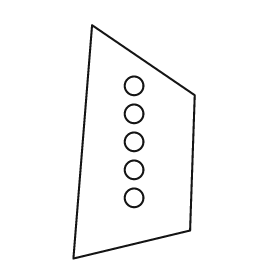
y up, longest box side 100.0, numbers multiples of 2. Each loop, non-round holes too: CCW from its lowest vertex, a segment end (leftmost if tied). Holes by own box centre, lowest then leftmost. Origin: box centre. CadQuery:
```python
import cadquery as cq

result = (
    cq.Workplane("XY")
    .moveTo(-26.0, -50.0)
    .lineTo(24.0, -38.0)
    .lineTo(26.0, 20.0)
    .lineTo(-18.0, 50.0)
    .close()
    .moveTo(0.0, -24.0)
    .circle(4.0)
    .moveTo(0.0, -12.0)
    .circle(4.0)
    .moveTo(0.0, 0.0)
    .circle(4.0)
    .moveTo(0.0, 12.0)
    .circle(4.0)
    .moveTo(0.0, 24.0)
    .circle(4.0)
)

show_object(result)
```